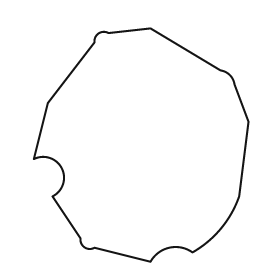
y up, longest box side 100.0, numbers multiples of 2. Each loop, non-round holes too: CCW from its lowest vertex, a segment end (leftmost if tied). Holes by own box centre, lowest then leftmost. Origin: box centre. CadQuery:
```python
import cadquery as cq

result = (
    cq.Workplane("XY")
    .moveTo(4.0, -50.0)
    .threePointArc((12.0, -44.0), (22.0, -46.0))
    .threePointArc((34.0, -36.0), (42.0, -22.0))
    .lineTo(46.0, 10.0)
    .lineTo(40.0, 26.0)
    .threePointArc((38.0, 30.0), (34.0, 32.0))
    .lineTo(4.0, 50.0)
    .lineTo(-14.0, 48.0)
    .threePointArc((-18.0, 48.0), (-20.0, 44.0))
    .lineTo(-40.0, 18.0)
    .lineTo(-46.0, -6.0)
    .threePointArc((-34.0, -10.0), (-38.0, -22.0))
    .lineTo(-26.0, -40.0)
    .threePointArc((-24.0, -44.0), (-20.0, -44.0))
    .close()
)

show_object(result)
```